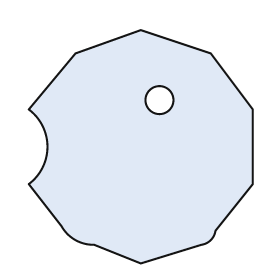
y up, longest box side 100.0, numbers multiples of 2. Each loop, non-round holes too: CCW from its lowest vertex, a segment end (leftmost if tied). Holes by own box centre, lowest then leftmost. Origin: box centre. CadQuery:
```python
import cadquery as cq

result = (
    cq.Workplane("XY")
    .moveTo(0.0, -50.0)
    .lineTo(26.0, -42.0)
    .threePointArc((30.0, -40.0), (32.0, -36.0))
    .lineTo(48.0, -16.0)
    .lineTo(48.0, 16.0)
    .lineTo(30.0, 40.0)
    .lineTo(0.0, 50.0)
    .lineTo(-28.0, 40.0)
    .lineTo(-48.0, 16.0)
    .threePointArc((-40.0, 0.0), (-48.0, -16.0))
    .lineTo(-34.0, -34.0)
    .threePointArc((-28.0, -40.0), (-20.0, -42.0))
    .close()
    .moveTo(8.0, 20.0)
    .circle(6.0)
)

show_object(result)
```